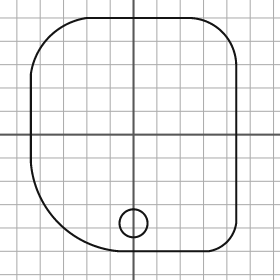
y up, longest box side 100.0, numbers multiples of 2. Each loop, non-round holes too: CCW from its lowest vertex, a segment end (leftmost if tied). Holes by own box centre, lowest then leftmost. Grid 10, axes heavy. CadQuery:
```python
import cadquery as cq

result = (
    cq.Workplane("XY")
    .moveTo(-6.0, -50.0)
    .lineTo(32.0, -50.0)
    .threePointArc((40.0, -46.0), (44.0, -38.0))
    .lineTo(44.0, 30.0)
    .threePointArc((38.0, 44.0), (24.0, 50.0))
    .lineTo(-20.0, 50.0)
    .threePointArc((-36.0, 42.0), (-44.0, 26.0))
    .lineTo(-44.0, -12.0)
    .threePointArc((-32.0, -38.0), (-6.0, -50.0))
    .close()
    .moveTo(0.0, -38.0)
    .circle(6.0)
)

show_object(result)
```